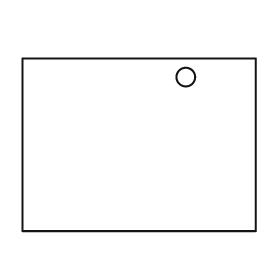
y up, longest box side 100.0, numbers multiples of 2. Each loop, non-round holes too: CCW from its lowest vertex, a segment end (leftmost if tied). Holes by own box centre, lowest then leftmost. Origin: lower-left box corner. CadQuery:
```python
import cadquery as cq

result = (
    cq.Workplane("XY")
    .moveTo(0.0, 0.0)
    .lineTo(100.0, 0.0)
    .lineTo(100.0, 74.0)
    .lineTo(0.0, 74.0)
    .close()
    .moveTo(70.0, 66.0)
    .circle(4.0)
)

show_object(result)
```